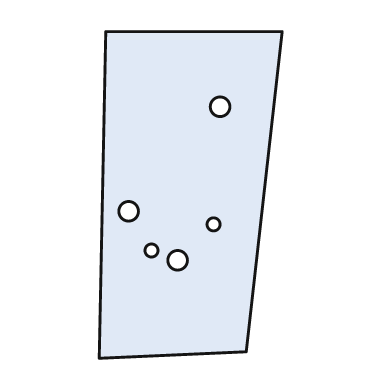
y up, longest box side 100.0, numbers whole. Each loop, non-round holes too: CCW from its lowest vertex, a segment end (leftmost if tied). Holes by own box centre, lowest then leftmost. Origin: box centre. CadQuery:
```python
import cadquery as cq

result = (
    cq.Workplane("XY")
    .moveTo(-28.0, -50.0)
    .lineTo(17.0, -48.0)
    .lineTo(28.0, 50.0)
    .lineTo(-26.0, 50.0)
    .close()
    .moveTo(-4.0, -20.0)
    .circle(3.0)
    .moveTo(-12.0, -17.0)
    .circle(2.0)
    .moveTo(7.0, -9.0)
    .circle(2.0)
    .moveTo(-19.0, -5.0)
    .circle(3.0)
    .moveTo(9.0, 27.0)
    .circle(3.0)
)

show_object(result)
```